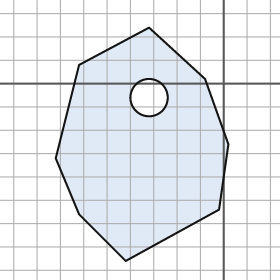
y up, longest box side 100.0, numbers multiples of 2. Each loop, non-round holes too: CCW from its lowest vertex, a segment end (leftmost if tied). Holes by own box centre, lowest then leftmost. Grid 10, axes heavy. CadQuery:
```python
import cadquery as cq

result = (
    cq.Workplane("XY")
    .moveTo(-42.0, -76.0)
    .lineTo(-2.0, -54.0)
    .lineTo(2.0, -26.0)
    .lineTo(-8.0, 2.0)
    .lineTo(-32.0, 24.0)
    .lineTo(-62.0, 8.0)
    .lineTo(-72.0, -32.0)
    .lineTo(-62.0, -56.0)
    .close()
    .moveTo(-32.0, -6.0)
    .circle(8.0)
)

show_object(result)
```